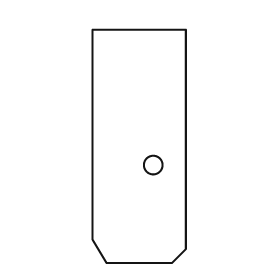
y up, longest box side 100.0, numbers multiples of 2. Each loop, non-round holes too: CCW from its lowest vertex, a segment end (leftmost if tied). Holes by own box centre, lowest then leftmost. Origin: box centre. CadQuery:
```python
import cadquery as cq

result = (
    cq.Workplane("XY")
    .moveTo(-14.0, -50.0)
    .lineTo(14.0, -50.0)
    .lineTo(20.0, -44.0)
    .lineTo(20.0, 50.0)
    .lineTo(-20.0, 50.0)
    .lineTo(-20.0, -40.0)
    .close()
    .moveTo(6.0, -8.0)
    .circle(4.0)
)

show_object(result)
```